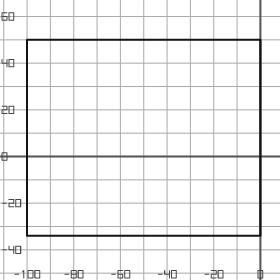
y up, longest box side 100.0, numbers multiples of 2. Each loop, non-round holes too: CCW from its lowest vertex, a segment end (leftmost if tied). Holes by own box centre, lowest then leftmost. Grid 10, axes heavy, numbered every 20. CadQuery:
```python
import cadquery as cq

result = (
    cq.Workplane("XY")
    .moveTo(-100.0, -34.0)
    .lineTo(0.0, -34.0)
    .lineTo(0.0, 50.0)
    .lineTo(-100.0, 50.0)
    .close()
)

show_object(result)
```